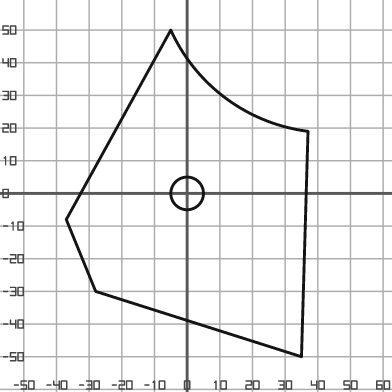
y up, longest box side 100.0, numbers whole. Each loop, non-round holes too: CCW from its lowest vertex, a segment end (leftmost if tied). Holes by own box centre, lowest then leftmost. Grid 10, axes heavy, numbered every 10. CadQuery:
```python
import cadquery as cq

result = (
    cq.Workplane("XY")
    .moveTo(35.0, -50.0)
    .lineTo(37.0, 19.0)
    .threePointArc((12.0, 29.0), (-5.0, 50.0))
    .lineTo(-37.0, -8.0)
    .lineTo(-28.0, -30.0)
    .close()
    .moveTo(0.0, 0.0)
    .circle(5.0)
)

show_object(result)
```